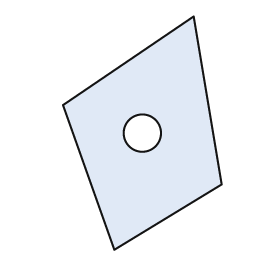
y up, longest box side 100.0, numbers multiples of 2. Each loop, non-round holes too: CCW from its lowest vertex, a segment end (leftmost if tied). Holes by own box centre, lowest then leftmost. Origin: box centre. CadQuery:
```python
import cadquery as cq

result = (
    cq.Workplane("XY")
    .moveTo(-12.0, -50.0)
    .lineTo(34.0, -22.0)
    .lineTo(22.0, 50.0)
    .lineTo(-34.0, 12.0)
    .close()
    .moveTo(0.0, 0.0)
    .circle(8.0)
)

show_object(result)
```